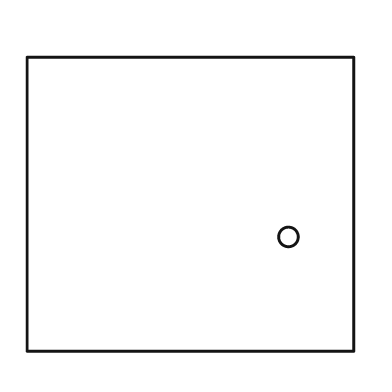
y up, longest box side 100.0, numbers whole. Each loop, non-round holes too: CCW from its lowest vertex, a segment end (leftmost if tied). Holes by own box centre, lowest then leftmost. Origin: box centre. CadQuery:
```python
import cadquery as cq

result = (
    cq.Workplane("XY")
    .moveTo(-50.0, -45.0)
    .lineTo(50.0, -45.0)
    .lineTo(50.0, 45.0)
    .lineTo(-50.0, 45.0)
    .close()
    .moveTo(30.0, -10.0)
    .circle(3.0)
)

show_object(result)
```